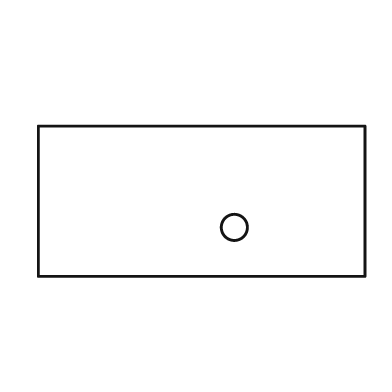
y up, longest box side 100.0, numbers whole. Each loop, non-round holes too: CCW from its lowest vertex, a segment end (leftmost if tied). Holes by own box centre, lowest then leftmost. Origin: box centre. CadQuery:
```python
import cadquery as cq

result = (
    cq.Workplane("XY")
    .moveTo(-50.0, -23.0)
    .lineTo(50.0, -23.0)
    .lineTo(50.0, 23.0)
    .lineTo(-50.0, 23.0)
    .close()
    .moveTo(10.0, -8.0)
    .circle(4.0)
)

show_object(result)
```